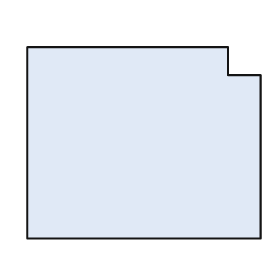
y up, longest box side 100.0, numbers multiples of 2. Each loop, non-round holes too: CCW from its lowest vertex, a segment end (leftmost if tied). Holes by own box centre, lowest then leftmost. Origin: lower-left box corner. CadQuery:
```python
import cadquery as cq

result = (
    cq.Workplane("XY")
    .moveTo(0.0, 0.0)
    .lineTo(100.0, 0.0)
    .lineTo(100.0, 70.0)
    .lineTo(86.0, 70.0)
    .lineTo(86.0, 82.0)
    .lineTo(0.0, 82.0)
    .close()
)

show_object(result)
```